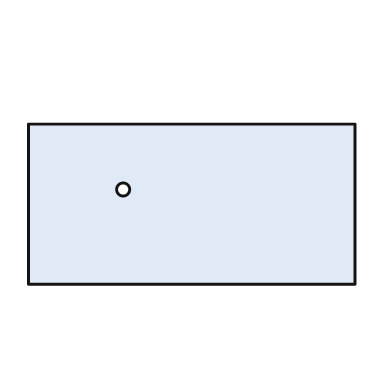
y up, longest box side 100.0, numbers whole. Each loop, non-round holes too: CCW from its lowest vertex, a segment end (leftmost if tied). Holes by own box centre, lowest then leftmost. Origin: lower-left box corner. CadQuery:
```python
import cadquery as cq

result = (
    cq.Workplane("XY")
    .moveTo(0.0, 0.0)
    .lineTo(100.0, 0.0)
    .lineTo(100.0, 49.0)
    .lineTo(0.0, 49.0)
    .close()
    .moveTo(29.0, 29.0)
    .circle(2.0)
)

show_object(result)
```